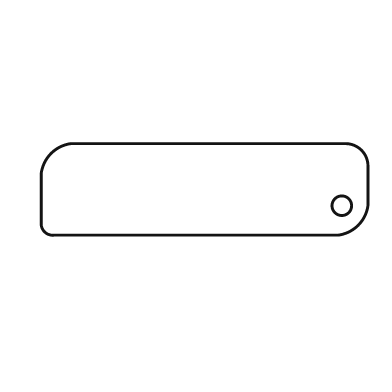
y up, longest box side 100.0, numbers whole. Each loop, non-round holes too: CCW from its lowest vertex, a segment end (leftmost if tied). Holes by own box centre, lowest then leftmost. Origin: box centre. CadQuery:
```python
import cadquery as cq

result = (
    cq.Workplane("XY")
    .moveTo(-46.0, -14.0)
    .lineTo(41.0, -14.0)
    .threePointArc((47.0, -11.0), (50.0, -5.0))
    .lineTo(50.0, 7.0)
    .threePointArc((48.0, 12.0), (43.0, 14.0))
    .lineTo(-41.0, 14.0)
    .threePointArc((-47.0, 11.0), (-50.0, 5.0))
    .lineTo(-50.0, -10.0)
    .threePointArc((-49.0, -13.0), (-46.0, -14.0))
    .close()
    .moveTo(42.0, -5.0)
    .circle(3.0)
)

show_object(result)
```